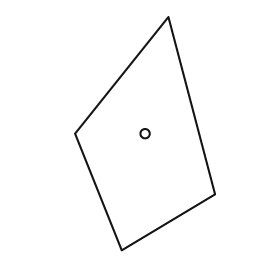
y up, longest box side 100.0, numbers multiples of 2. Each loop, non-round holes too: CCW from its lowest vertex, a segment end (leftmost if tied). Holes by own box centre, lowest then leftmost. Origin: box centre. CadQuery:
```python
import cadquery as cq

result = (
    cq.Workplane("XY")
    .moveTo(-10.0, -50.0)
    .lineTo(30.0, -26.0)
    .lineTo(10.0, 50.0)
    .lineTo(-30.0, 0.0)
    .close()
    .moveTo(0.0, 0.0)
    .circle(2.0)
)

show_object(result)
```